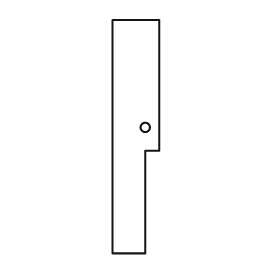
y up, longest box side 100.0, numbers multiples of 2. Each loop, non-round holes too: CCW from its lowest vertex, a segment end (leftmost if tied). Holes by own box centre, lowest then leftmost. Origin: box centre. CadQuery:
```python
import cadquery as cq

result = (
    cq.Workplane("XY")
    .moveTo(-10.0, -50.0)
    .lineTo(4.0, -50.0)
    .lineTo(4.0, -6.0)
    .lineTo(10.0, -6.0)
    .lineTo(10.0, 50.0)
    .lineTo(-10.0, 50.0)
    .close()
    .moveTo(4.0, 4.0)
    .circle(2.0)
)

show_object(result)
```